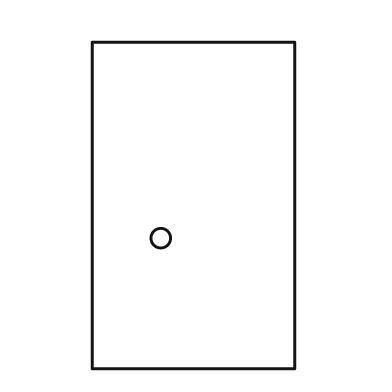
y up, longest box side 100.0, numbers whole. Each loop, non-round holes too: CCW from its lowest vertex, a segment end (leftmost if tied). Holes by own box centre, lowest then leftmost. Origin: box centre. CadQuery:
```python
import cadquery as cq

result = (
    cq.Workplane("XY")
    .moveTo(-31.0, -50.0)
    .lineTo(31.0, -50.0)
    .lineTo(31.0, 50.0)
    .lineTo(-31.0, 50.0)
    .close()
    .moveTo(-10.0, -10.0)
    .circle(3.0)
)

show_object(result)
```